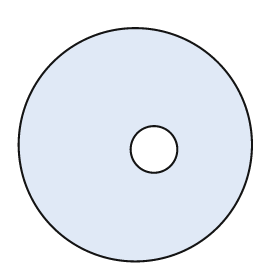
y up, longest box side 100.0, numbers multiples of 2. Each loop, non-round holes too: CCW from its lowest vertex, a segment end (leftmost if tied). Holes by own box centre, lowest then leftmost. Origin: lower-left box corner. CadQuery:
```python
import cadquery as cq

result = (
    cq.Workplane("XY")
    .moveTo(50.0, 50.0)
    .circle(50.0)
    .moveTo(58.0, 48.0)
    .circle(10.0)
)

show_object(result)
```